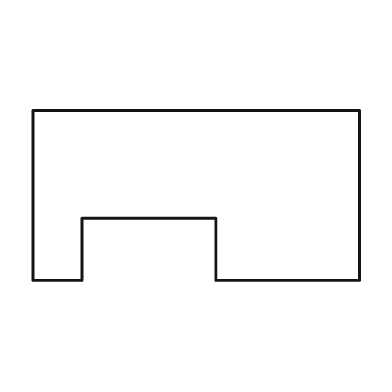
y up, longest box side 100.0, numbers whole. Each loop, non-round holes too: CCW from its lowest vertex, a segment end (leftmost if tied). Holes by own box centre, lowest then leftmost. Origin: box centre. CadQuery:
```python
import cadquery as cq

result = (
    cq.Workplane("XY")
    .moveTo(-50.0, -26.0)
    .lineTo(-35.0, -26.0)
    .lineTo(-35.0, -7.0)
    .lineTo(6.0, -7.0)
    .lineTo(6.0, -26.0)
    .lineTo(50.0, -26.0)
    .lineTo(50.0, 26.0)
    .lineTo(-50.0, 26.0)
    .close()
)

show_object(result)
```